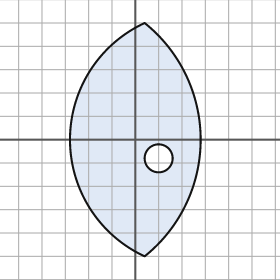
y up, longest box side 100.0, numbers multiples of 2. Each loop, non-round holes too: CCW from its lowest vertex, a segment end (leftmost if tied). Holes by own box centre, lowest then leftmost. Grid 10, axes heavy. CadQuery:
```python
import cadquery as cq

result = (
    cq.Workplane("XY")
    .moveTo(4.0, -50.0)
    .threePointArc((28.0, 0.0), (4.0, 50.0))
    .threePointArc((-28.0, 0.0), (4.0, -50.0))
    .close()
    .moveTo(10.0, -8.0)
    .circle(6.0)
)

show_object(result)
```